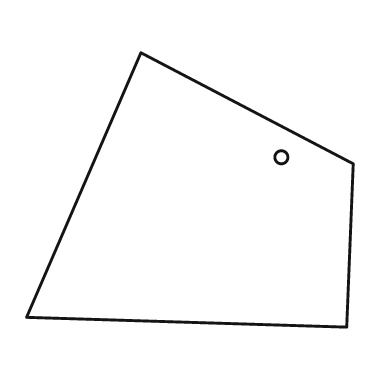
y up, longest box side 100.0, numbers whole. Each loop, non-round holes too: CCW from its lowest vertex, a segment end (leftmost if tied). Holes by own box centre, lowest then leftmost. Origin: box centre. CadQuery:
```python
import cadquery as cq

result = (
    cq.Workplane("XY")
    .moveTo(48.0, -42.0)
    .lineTo(50.0, 8.0)
    .lineTo(-15.0, 42.0)
    .lineTo(-50.0, -39.0)
    .close()
    .moveTo(28.0, 10.0)
    .circle(2.0)
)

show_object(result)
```